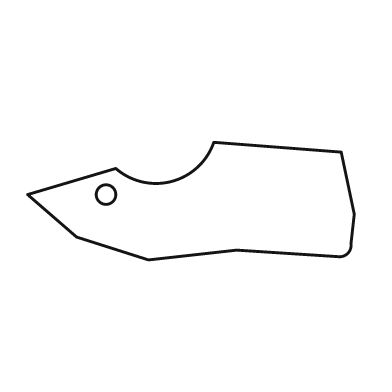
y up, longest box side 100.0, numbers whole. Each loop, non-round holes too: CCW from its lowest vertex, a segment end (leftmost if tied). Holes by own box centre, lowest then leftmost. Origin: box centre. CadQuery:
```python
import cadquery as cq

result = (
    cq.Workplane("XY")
    .moveTo(-13.0, -18.0)
    .lineTo(14.0, -15.0)
    .lineTo(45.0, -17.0)
    .threePointArc((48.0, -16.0), (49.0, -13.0))
    .lineTo(50.0, -4.0)
    .lineTo(46.0, 15.0)
    .lineTo(7.0, 18.0)
    .threePointArc((-6.0, 6.0), (-23.0, 10.0))
    .lineTo(-50.0, 2.0)
    .lineTo(-35.0, -11.0)
    .close()
    .moveTo(-26.0, 2.0)
    .circle(3.0)
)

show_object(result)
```